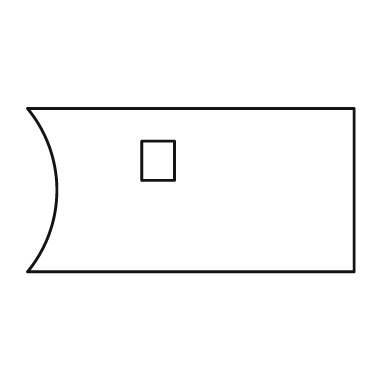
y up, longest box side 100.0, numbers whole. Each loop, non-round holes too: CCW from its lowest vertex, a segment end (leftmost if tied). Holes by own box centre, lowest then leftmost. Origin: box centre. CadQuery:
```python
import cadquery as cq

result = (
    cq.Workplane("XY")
    .moveTo(-50.0, -25.0)
    .lineTo(50.0, -25.0)
    .lineTo(50.0, 25.0)
    .lineTo(-50.0, 25.0)
    .threePointArc((-41.0, 0.0), (-50.0, -25.0))
    .close()
    .moveTo(-15.0, 3.0)
    .lineTo(-5.0, 3.0)
    .lineTo(-5.0, 15.0)
    .lineTo(-15.0, 15.0)
    .close()
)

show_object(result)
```